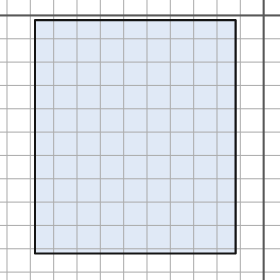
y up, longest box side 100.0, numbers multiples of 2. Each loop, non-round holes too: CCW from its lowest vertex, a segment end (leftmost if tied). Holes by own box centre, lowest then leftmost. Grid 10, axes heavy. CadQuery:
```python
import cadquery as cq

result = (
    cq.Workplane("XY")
    .moveTo(-98.0, -102.0)
    .lineTo(-12.0, -102.0)
    .lineTo(-12.0, -2.0)
    .lineTo(-98.0, -2.0)
    .close()
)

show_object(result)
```